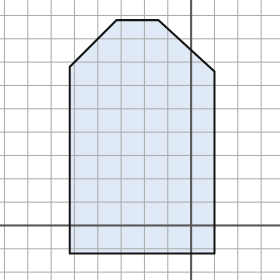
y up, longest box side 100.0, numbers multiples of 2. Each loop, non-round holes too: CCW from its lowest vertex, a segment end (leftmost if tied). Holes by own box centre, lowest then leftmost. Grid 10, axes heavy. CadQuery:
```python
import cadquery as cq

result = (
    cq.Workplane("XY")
    .moveTo(-52.0, -12.0)
    .lineTo(10.0, -12.0)
    .lineTo(10.0, 66.0)
    .lineTo(-14.0, 88.0)
    .lineTo(-32.0, 88.0)
    .lineTo(-52.0, 68.0)
    .close()
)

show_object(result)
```